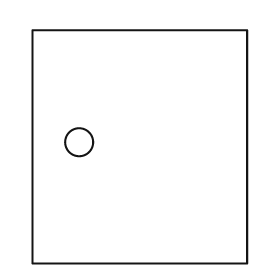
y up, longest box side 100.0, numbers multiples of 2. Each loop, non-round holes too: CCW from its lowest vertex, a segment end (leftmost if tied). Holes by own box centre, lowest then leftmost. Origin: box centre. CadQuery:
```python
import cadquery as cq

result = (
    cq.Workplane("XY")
    .moveTo(-46.0, -50.0)
    .lineTo(46.0, -50.0)
    .lineTo(46.0, 50.0)
    .lineTo(-46.0, 50.0)
    .close()
    .moveTo(-26.0, 2.0)
    .circle(6.0)
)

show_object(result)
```